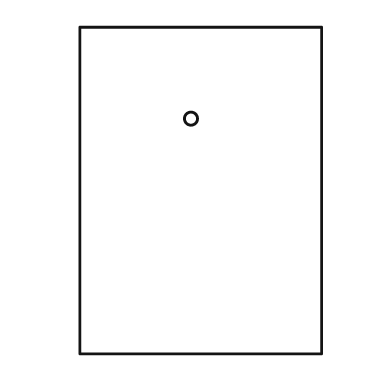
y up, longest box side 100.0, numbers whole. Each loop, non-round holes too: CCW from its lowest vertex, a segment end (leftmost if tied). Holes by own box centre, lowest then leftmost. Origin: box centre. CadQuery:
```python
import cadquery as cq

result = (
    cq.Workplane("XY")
    .moveTo(-37.0, -50.0)
    .lineTo(37.0, -50.0)
    .lineTo(37.0, 50.0)
    .lineTo(-37.0, 50.0)
    .close()
    .moveTo(-3.0, 22.0)
    .circle(2.0)
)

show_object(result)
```